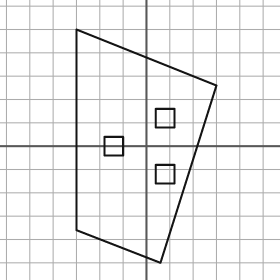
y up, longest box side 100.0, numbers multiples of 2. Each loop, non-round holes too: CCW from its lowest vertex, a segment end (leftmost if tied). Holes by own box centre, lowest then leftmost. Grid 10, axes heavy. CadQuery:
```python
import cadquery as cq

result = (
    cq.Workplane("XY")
    .moveTo(6.0, -50.0)
    .lineTo(30.0, 26.0)
    .lineTo(-30.0, 50.0)
    .lineTo(-30.0, -36.0)
    .close()
    .moveTo(4.0, -16.0)
    .lineTo(12.0, -16.0)
    .lineTo(12.0, -8.0)
    .lineTo(4.0, -8.0)
    .close()
    .moveTo(-18.0, -4.0)
    .lineTo(-10.0, -4.0)
    .lineTo(-10.0, 4.0)
    .lineTo(-18.0, 4.0)
    .close()
    .moveTo(4.0, 8.0)
    .lineTo(12.0, 8.0)
    .lineTo(12.0, 16.0)
    .lineTo(4.0, 16.0)
    .close()
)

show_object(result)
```